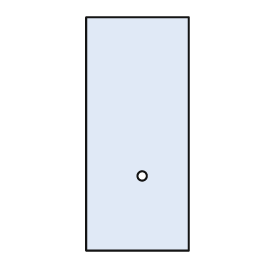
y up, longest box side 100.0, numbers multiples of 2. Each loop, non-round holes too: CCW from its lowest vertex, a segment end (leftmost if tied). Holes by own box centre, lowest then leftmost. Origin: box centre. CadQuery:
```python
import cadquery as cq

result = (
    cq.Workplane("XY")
    .moveTo(-22.0, -50.0)
    .lineTo(22.0, -50.0)
    .lineTo(22.0, 50.0)
    .lineTo(-22.0, 50.0)
    .close()
    .moveTo(2.0, -18.0)
    .circle(2.0)
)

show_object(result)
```